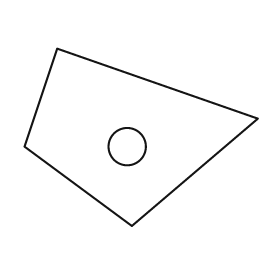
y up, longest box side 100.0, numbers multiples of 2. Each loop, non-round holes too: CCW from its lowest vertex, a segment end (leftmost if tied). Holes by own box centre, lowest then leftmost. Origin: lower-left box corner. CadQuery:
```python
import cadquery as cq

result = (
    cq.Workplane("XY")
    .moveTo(46.0, 0.0)
    .lineTo(100.0, 46.0)
    .lineTo(14.0, 76.0)
    .lineTo(0.0, 34.0)
    .close()
    .moveTo(44.0, 34.0)
    .circle(8.0)
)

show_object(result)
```